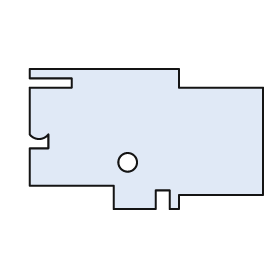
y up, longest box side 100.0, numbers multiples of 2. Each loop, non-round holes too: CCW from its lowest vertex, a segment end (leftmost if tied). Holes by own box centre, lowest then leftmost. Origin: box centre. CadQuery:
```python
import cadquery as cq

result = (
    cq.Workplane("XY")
    .moveTo(-14.0, -30.0)
    .lineTo(4.0, -30.0)
    .lineTo(4.0, -22.0)
    .lineTo(10.0, -22.0)
    .lineTo(10.0, -30.0)
    .lineTo(14.0, -30.0)
    .lineTo(14.0, -24.0)
    .lineTo(50.0, -24.0)
    .lineTo(50.0, 22.0)
    .lineTo(14.0, 22.0)
    .lineTo(14.0, 30.0)
    .lineTo(-50.0, 30.0)
    .lineTo(-50.0, 26.0)
    .lineTo(-32.0, 26.0)
    .lineTo(-32.0, 22.0)
    .lineTo(-50.0, 22.0)
    .lineTo(-50.0, 2.0)
    .threePointArc((-46.0, 0.0), (-42.0, 2.0))
    .lineTo(-42.0, -4.0)
    .lineTo(-50.0, -4.0)
    .lineTo(-50.0, -20.0)
    .lineTo(-14.0, -20.0)
    .close()
    .moveTo(-8.0, -10.0)
    .circle(4.0)
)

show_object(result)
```